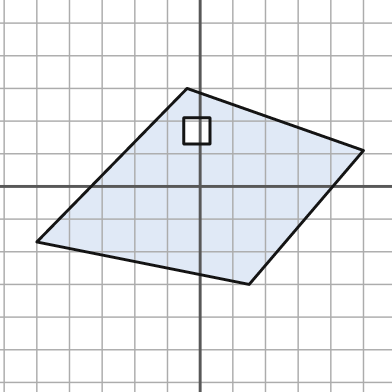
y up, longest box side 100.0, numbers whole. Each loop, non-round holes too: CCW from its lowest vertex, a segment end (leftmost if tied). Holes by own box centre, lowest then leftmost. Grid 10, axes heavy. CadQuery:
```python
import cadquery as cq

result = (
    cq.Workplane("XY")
    .moveTo(15.0, -30.0)
    .lineTo(50.0, 11.0)
    .lineTo(-4.0, 30.0)
    .lineTo(-50.0, -17.0)
    .close()
    .moveTo(-5.0, 13.0)
    .lineTo(3.0, 13.0)
    .lineTo(3.0, 21.0)
    .lineTo(-5.0, 21.0)
    .close()
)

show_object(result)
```